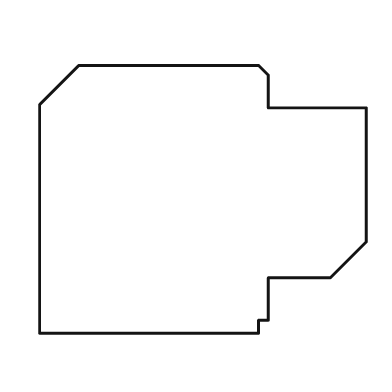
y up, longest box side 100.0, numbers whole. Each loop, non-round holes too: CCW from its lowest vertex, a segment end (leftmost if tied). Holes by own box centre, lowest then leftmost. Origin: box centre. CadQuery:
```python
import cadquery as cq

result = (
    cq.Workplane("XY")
    .moveTo(-50.0, -41.0)
    .lineTo(17.0, -41.0)
    .lineTo(17.0, -37.0)
    .lineTo(20.0, -37.0)
    .lineTo(20.0, -24.0)
    .lineTo(39.0, -24.0)
    .lineTo(50.0, -13.0)
    .lineTo(50.0, 28.0)
    .lineTo(20.0, 28.0)
    .lineTo(20.0, 38.0)
    .lineTo(17.0, 41.0)
    .lineTo(-38.0, 41.0)
    .lineTo(-50.0, 29.0)
    .close()
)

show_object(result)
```